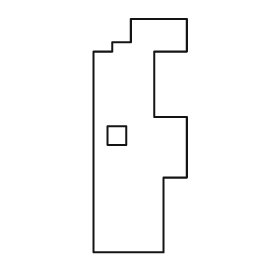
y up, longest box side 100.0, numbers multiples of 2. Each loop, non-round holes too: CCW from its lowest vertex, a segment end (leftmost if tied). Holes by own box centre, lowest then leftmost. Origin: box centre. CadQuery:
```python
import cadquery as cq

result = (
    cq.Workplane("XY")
    .moveTo(-20.0, -50.0)
    .lineTo(10.0, -50.0)
    .lineTo(10.0, -18.0)
    .lineTo(20.0, -18.0)
    .lineTo(20.0, 8.0)
    .lineTo(6.0, 8.0)
    .lineTo(6.0, 36.0)
    .lineTo(20.0, 36.0)
    .lineTo(20.0, 50.0)
    .lineTo(-4.0, 50.0)
    .lineTo(-4.0, 40.0)
    .lineTo(-12.0, 40.0)
    .lineTo(-12.0, 36.0)
    .lineTo(-20.0, 36.0)
    .close()
    .moveTo(-14.0, -4.0)
    .lineTo(-6.0, -4.0)
    .lineTo(-6.0, 4.0)
    .lineTo(-14.0, 4.0)
    .close()
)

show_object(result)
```